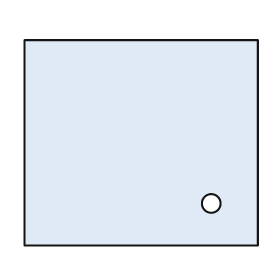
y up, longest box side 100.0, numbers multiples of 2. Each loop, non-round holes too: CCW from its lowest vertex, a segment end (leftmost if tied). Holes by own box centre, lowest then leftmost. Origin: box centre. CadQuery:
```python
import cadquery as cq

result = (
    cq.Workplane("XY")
    .moveTo(-50.0, -44.0)
    .lineTo(50.0, -44.0)
    .lineTo(50.0, 44.0)
    .lineTo(-50.0, 44.0)
    .close()
    .moveTo(30.0, -26.0)
    .circle(4.0)
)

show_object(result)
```